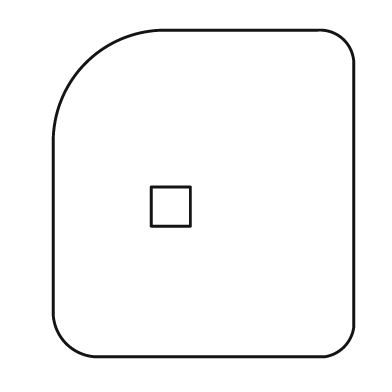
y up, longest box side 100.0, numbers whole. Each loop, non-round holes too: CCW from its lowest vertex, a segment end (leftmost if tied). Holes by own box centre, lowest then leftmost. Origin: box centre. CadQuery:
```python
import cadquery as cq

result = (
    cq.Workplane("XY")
    .moveTo(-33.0, -50.0)
    .lineTo(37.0, -50.0)
    .threePointArc((43.0, -47.0), (46.0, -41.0))
    .lineTo(46.0, 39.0)
    .threePointArc((43.0, 47.0), (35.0, 50.0))
    .lineTo(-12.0, 50.0)
    .threePointArc((-36.0, 40.0), (-46.0, 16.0))
    .lineTo(-46.0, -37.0)
    .threePointArc((-42.0, -46.0), (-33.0, -50.0))
    .close()
    .moveTo(-16.0, -10.0)
    .lineTo(-4.0, -10.0)
    .lineTo(-4.0, 2.0)
    .lineTo(-16.0, 2.0)
    .close()
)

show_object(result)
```